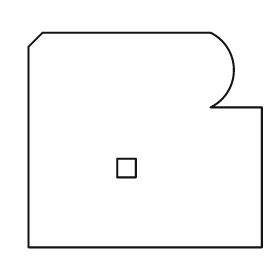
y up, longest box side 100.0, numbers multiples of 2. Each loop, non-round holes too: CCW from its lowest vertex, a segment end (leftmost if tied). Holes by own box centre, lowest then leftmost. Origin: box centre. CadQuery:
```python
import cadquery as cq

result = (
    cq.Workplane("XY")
    .moveTo(-50.0, -46.0)
    .lineTo(50.0, -46.0)
    .lineTo(50.0, 14.0)
    .lineTo(28.0, 14.0)
    .threePointArc((38.0, 30.0), (28.0, 46.0))
    .lineTo(-44.0, 46.0)
    .lineTo(-50.0, 40.0)
    .close()
    .moveTo(-12.0, -16.0)
    .lineTo(-4.0, -16.0)
    .lineTo(-4.0, -8.0)
    .lineTo(-12.0, -8.0)
    .close()
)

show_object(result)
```